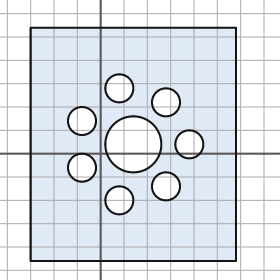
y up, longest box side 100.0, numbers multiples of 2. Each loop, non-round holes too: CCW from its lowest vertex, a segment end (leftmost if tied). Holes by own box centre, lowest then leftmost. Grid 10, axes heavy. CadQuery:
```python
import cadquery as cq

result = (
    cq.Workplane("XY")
    .moveTo(-30.0, -46.0)
    .lineTo(58.0, -46.0)
    .lineTo(58.0, 54.0)
    .lineTo(-30.0, 54.0)
    .close()
    .moveTo(8.0, -20.0)
    .circle(6.0)
    .moveTo(28.0, -14.0)
    .circle(6.0)
    .moveTo(-8.0, -6.0)
    .circle(6.0)
    .moveTo(14.0, 4.0)
    .circle(12.0)
    .moveTo(38.0, 4.0)
    .circle(6.0)
    .moveTo(-8.0, 14.0)
    .circle(6.0)
    .moveTo(28.0, 22.0)
    .circle(6.0)
    .moveTo(8.0, 28.0)
    .circle(6.0)
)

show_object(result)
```